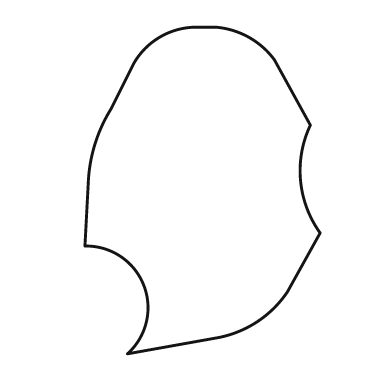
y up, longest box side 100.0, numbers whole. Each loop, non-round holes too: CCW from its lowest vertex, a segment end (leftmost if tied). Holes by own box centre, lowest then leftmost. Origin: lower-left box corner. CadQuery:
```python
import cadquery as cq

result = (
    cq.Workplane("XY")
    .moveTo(13.0, 0.0)
    .lineTo(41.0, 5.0)
    .threePointArc((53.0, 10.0), (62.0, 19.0))
    .lineTo(72.0, 37.0)
    .threePointArc((66.0, 53.0), (69.0, 70.0))
    .lineTo(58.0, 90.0)
    .threePointArc((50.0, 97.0), (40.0, 100.0))
    .lineTo(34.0, 100.0)
    .threePointArc((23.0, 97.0), (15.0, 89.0))
    .lineTo(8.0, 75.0)
    .threePointArc((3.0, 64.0), (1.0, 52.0))
    .lineTo(0.0, 33.0)
    .threePointArc((18.0, 21.0), (13.0, 0.0))
    .close()
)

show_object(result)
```